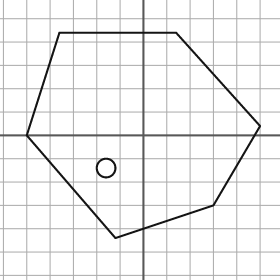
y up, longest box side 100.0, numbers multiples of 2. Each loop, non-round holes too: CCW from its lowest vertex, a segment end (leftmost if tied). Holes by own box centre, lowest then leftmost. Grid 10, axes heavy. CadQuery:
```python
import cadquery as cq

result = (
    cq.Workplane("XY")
    .moveTo(-12.0, -44.0)
    .lineTo(30.0, -30.0)
    .lineTo(50.0, 4.0)
    .lineTo(14.0, 44.0)
    .lineTo(-36.0, 44.0)
    .lineTo(-50.0, 0.0)
    .close()
    .moveTo(-16.0, -14.0)
    .circle(4.0)
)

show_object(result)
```